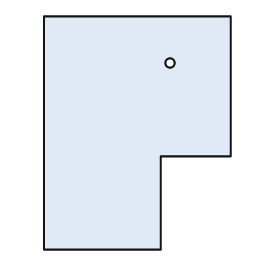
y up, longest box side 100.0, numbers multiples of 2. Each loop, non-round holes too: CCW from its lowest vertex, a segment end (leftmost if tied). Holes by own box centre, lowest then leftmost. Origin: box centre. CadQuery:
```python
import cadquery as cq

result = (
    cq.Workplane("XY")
    .moveTo(-40.0, -50.0)
    .lineTo(10.0, -50.0)
    .lineTo(10.0, -10.0)
    .lineTo(40.0, -10.0)
    .lineTo(40.0, 50.0)
    .lineTo(-40.0, 50.0)
    .close()
    .moveTo(14.0, 30.0)
    .circle(2.0)
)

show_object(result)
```